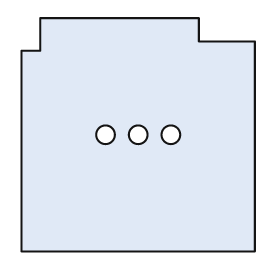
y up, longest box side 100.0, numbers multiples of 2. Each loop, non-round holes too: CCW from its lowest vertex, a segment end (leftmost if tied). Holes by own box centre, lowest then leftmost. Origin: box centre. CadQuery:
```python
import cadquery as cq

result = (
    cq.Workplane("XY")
    .moveTo(-50.0, -50.0)
    .lineTo(50.0, -50.0)
    .lineTo(50.0, 40.0)
    .lineTo(26.0, 40.0)
    .lineTo(26.0, 50.0)
    .lineTo(-42.0, 50.0)
    .lineTo(-42.0, 36.0)
    .lineTo(-50.0, 36.0)
    .close()
    .moveTo(-14.0, 0.0)
    .circle(4.0)
    .moveTo(0.0, 0.0)
    .circle(4.0)
    .moveTo(14.0, 0.0)
    .circle(4.0)
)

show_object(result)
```